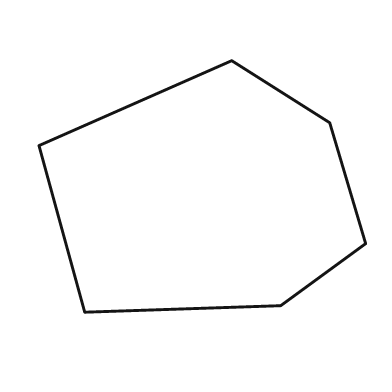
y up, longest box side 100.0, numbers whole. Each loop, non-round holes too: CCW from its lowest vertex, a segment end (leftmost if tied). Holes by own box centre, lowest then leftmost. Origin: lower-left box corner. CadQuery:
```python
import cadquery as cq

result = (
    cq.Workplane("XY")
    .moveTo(14.0, 0.0)
    .lineTo(74.0, 2.0)
    .lineTo(100.0, 21.0)
    .lineTo(89.0, 58.0)
    .lineTo(59.0, 77.0)
    .lineTo(0.0, 51.0)
    .close()
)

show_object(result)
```